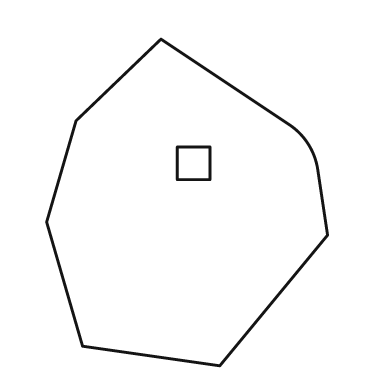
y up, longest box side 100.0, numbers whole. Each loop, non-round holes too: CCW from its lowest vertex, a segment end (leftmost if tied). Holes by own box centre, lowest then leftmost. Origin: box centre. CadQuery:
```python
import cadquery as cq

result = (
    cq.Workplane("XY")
    .moveTo(10.0, -50.0)
    .lineTo(43.0, -10.0)
    .lineTo(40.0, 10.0)
    .threePointArc((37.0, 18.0), (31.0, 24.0))
    .lineTo(-8.0, 50.0)
    .lineTo(-34.0, 25.0)
    .lineTo(-43.0, -6.0)
    .lineTo(-32.0, -44.0)
    .close()
    .moveTo(-3.0, 7.0)
    .lineTo(7.0, 7.0)
    .lineTo(7.0, 17.0)
    .lineTo(-3.0, 17.0)
    .close()
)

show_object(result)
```